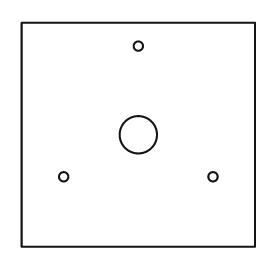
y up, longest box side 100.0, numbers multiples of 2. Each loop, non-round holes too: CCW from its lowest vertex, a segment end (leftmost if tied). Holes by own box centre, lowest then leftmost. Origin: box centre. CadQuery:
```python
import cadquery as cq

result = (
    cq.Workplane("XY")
    .moveTo(-50.0, -48.0)
    .lineTo(50.0, -48.0)
    .lineTo(50.0, 48.0)
    .lineTo(-50.0, 48.0)
    .close()
    .moveTo(-32.0, -18.0)
    .circle(2.0)
    .moveTo(32.0, -18.0)
    .circle(2.0)
    .moveTo(0.0, 0.0)
    .circle(8.0)
    .moveTo(0.0, 38.0)
    .circle(2.0)
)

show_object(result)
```